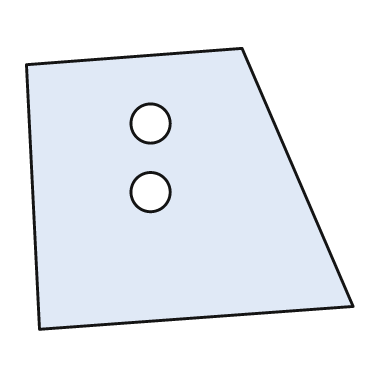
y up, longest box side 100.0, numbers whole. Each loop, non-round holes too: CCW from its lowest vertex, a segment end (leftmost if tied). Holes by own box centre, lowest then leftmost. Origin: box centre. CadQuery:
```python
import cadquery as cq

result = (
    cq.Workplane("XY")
    .moveTo(-46.0, -43.0)
    .lineTo(50.0, -36.0)
    .lineTo(16.0, 43.0)
    .lineTo(-50.0, 38.0)
    .close()
    .moveTo(-12.0, -1.0)
    .circle(6.0)
    .moveTo(-12.0, 20.0)
    .circle(6.0)
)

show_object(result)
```